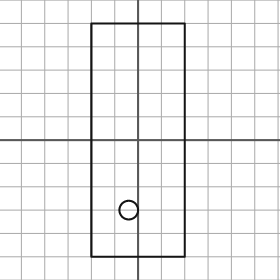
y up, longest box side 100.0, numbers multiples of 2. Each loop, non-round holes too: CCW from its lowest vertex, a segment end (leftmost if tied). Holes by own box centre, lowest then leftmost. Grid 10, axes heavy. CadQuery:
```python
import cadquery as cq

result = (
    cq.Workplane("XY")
    .moveTo(-20.0, -50.0)
    .lineTo(20.0, -50.0)
    .lineTo(20.0, 50.0)
    .lineTo(-20.0, 50.0)
    .close()
    .moveTo(-4.0, -30.0)
    .circle(4.0)
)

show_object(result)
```